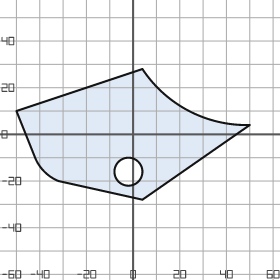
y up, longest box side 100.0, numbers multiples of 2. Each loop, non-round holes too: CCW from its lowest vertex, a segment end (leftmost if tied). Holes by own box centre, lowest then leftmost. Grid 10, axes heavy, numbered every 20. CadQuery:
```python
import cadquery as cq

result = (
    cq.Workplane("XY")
    .moveTo(4.0, -28.0)
    .lineTo(50.0, 4.0)
    .threePointArc((24.0, 10.0), (4.0, 28.0))
    .lineTo(-50.0, 10.0)
    .lineTo(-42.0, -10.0)
    .threePointArc((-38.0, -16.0), (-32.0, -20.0))
    .close()
    .moveTo(-2.0, -16.0)
    .circle(6.0)
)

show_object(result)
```